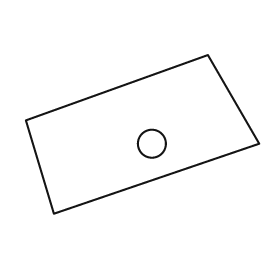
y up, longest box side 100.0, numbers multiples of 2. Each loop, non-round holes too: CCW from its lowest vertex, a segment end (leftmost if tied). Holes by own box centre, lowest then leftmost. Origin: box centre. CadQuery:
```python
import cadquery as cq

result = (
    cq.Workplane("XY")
    .moveTo(-38.0, -34.0)
    .lineTo(50.0, -4.0)
    .lineTo(28.0, 34.0)
    .lineTo(-50.0, 6.0)
    .close()
    .moveTo(4.0, -4.0)
    .circle(6.0)
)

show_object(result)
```